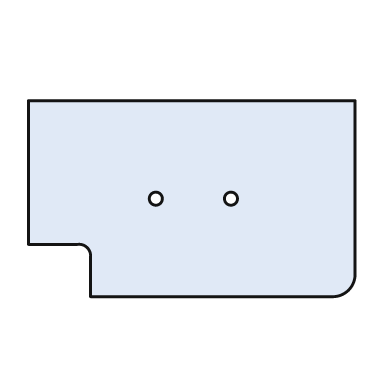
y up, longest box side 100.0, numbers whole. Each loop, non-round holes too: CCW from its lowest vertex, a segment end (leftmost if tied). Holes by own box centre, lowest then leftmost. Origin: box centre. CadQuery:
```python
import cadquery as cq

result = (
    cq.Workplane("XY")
    .moveTo(-31.0, -30.0)
    .lineTo(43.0, -30.0)
    .threePointArc((48.0, -28.0), (50.0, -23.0))
    .lineTo(50.0, 30.0)
    .lineTo(-50.0, 30.0)
    .lineTo(-50.0, -14.0)
    .lineTo(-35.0, -14.0)
    .threePointArc((-32.0, -15.0), (-31.0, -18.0))
    .close()
    .moveTo(-11.0, 0.0)
    .circle(2.0)
    .moveTo(12.0, 0.0)
    .circle(2.0)
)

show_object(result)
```